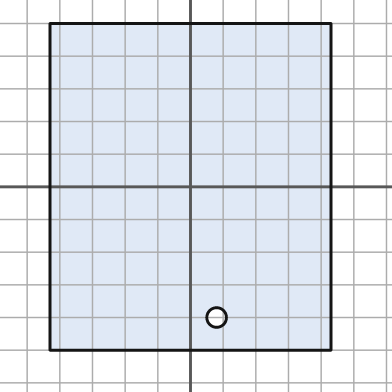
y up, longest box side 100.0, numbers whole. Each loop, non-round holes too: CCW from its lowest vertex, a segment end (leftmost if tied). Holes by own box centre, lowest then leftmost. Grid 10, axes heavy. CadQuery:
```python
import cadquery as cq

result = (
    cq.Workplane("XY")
    .moveTo(-43.0, -50.0)
    .lineTo(43.0, -50.0)
    .lineTo(43.0, 50.0)
    .lineTo(-43.0, 50.0)
    .close()
    .moveTo(8.0, -40.0)
    .circle(3.0)
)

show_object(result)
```